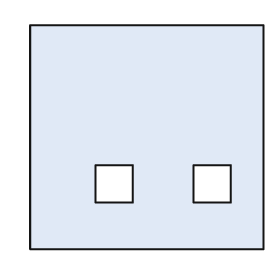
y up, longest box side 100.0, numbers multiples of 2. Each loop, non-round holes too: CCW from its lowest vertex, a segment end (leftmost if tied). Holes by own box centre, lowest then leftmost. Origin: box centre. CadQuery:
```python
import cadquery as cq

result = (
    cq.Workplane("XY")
    .moveTo(-50.0, -48.0)
    .lineTo(50.0, -48.0)
    .lineTo(50.0, 48.0)
    .lineTo(-50.0, 48.0)
    .close()
    .moveTo(-22.0, -28.0)
    .lineTo(-6.0, -28.0)
    .lineTo(-6.0, -12.0)
    .lineTo(-22.0, -12.0)
    .close()
    .moveTo(20.0, -28.0)
    .lineTo(36.0, -28.0)
    .lineTo(36.0, -12.0)
    .lineTo(20.0, -12.0)
    .close()
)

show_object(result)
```